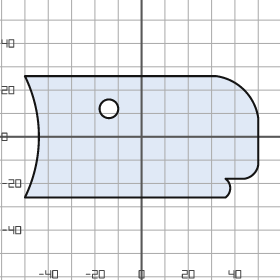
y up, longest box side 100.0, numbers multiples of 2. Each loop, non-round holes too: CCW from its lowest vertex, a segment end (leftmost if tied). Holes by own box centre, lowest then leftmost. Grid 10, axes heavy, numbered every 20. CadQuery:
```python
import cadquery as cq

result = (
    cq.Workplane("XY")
    .moveTo(-50.0, -26.0)
    .lineTo(36.0, -26.0)
    .threePointArc((38.0, -22.0), (36.0, -18.0))
    .lineTo(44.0, -18.0)
    .threePointArc((48.0, -16.0), (50.0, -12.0))
    .lineTo(50.0, 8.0)
    .threePointArc((44.0, 20.0), (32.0, 26.0))
    .lineTo(-50.0, 26.0)
    .threePointArc((-44.0, 0.0), (-50.0, -26.0))
    .close()
    .moveTo(-14.0, 12.0)
    .circle(4.0)
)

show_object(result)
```